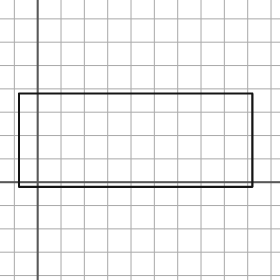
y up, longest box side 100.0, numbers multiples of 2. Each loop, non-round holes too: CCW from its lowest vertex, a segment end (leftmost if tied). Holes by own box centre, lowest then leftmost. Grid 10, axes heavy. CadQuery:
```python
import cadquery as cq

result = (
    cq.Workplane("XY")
    .moveTo(-8.0, -2.0)
    .lineTo(92.0, -2.0)
    .lineTo(92.0, 38.0)
    .lineTo(-8.0, 38.0)
    .close()
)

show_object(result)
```